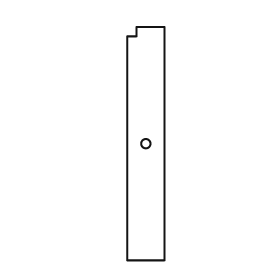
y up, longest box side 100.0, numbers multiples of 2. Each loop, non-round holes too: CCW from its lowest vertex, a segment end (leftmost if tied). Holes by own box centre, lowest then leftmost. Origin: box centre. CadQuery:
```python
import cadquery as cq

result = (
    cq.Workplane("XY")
    .moveTo(-8.0, -50.0)
    .lineTo(8.0, -50.0)
    .lineTo(8.0, 50.0)
    .lineTo(-4.0, 50.0)
    .lineTo(-4.0, 46.0)
    .lineTo(-8.0, 46.0)
    .close()
    .moveTo(0.0, 0.0)
    .circle(2.0)
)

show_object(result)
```